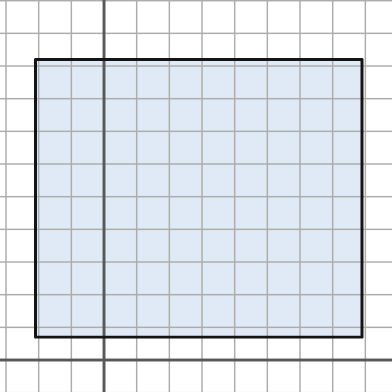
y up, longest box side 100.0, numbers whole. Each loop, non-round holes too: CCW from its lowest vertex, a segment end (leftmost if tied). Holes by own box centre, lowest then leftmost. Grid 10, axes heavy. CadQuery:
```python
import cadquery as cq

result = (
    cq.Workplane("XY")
    .moveTo(-21.0, 7.0)
    .lineTo(79.0, 7.0)
    .lineTo(79.0, 92.0)
    .lineTo(-21.0, 92.0)
    .close()
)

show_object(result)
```